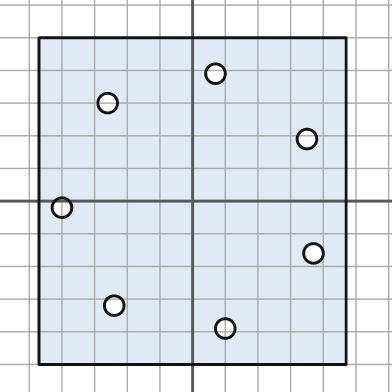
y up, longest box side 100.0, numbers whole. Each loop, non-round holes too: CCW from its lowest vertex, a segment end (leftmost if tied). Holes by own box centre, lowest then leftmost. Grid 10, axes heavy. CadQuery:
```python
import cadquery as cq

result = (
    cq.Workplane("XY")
    .moveTo(-47.0, -50.0)
    .lineTo(47.0, -50.0)
    .lineTo(47.0, 50.0)
    .lineTo(-47.0, 50.0)
    .close()
    .moveTo(10.0, -39.0)
    .circle(3.0)
    .moveTo(-24.0, -32.0)
    .circle(3.0)
    .moveTo(37.0, -16.0)
    .circle(3.0)
    .moveTo(-40.0, -2.0)
    .circle(3.0)
    .moveTo(35.0, 19.0)
    .circle(3.0)
    .moveTo(-26.0, 30.0)
    .circle(3.0)
    .moveTo(7.0, 39.0)
    .circle(3.0)
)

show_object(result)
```